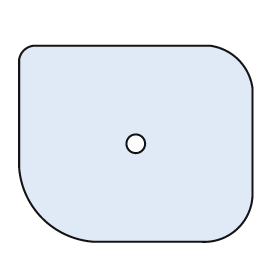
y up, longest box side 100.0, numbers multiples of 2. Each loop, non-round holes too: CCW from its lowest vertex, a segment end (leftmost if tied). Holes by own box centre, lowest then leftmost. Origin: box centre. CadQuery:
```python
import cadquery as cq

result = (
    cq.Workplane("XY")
    .moveTo(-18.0, -42.0)
    .lineTo(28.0, -42.0)
    .threePointArc((44.0, -36.0), (50.0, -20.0))
    .lineTo(50.0, 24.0)
    .threePointArc((44.0, 36.0), (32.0, 42.0))
    .lineTo(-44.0, 42.0)
    .threePointArc((-48.0, 40.0), (-50.0, 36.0))
    .lineTo(-50.0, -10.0)
    .threePointArc((-40.0, -32.0), (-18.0, -42.0))
    .close()
    .moveTo(0.0, 0.0)
    .circle(4.0)
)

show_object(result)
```